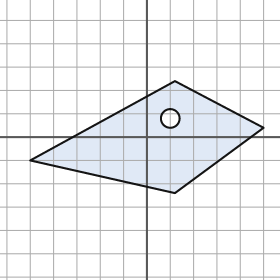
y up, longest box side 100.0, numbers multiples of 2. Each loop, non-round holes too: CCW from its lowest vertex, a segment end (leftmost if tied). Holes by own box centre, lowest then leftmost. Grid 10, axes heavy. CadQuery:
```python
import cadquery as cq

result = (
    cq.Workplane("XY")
    .moveTo(12.0, -24.0)
    .lineTo(50.0, 4.0)
    .lineTo(12.0, 24.0)
    .lineTo(-50.0, -10.0)
    .close()
    .moveTo(10.0, 8.0)
    .circle(4.0)
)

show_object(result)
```